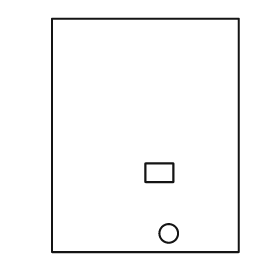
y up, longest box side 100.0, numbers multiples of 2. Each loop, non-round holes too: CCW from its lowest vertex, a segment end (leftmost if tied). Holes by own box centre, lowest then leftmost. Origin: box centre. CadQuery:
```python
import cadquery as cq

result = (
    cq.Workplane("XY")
    .moveTo(-40.0, -50.0)
    .lineTo(40.0, -50.0)
    .lineTo(40.0, 50.0)
    .lineTo(-40.0, 50.0)
    .close()
    .moveTo(10.0, -42.0)
    .circle(4.0)
    .moveTo(0.0, -20.0)
    .lineTo(12.0, -20.0)
    .lineTo(12.0, -12.0)
    .lineTo(0.0, -12.0)
    .close()
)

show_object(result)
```